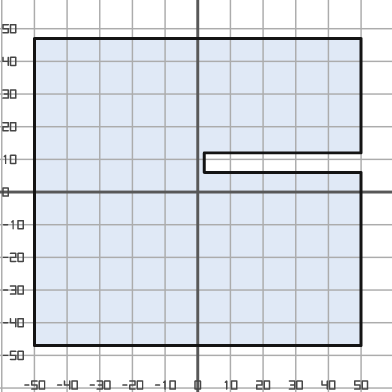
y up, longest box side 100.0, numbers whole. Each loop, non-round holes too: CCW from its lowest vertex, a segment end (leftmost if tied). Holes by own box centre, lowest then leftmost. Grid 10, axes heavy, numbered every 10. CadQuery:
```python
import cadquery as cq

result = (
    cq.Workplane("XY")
    .moveTo(-50.0, -47.0)
    .lineTo(50.0, -47.0)
    .lineTo(50.0, 6.0)
    .lineTo(2.0, 6.0)
    .lineTo(2.0, 12.0)
    .lineTo(50.0, 12.0)
    .lineTo(50.0, 47.0)
    .lineTo(-50.0, 47.0)
    .close()
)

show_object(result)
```